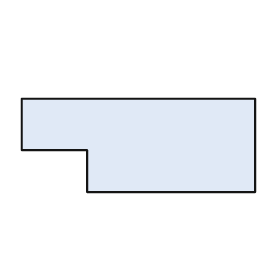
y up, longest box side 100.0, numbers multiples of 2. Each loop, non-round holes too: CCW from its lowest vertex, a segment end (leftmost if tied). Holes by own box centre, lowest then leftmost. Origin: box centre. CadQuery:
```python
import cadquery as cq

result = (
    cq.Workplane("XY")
    .moveTo(-22.0, -20.0)
    .lineTo(50.0, -20.0)
    .lineTo(50.0, 20.0)
    .lineTo(-50.0, 20.0)
    .lineTo(-50.0, -2.0)
    .lineTo(-22.0, -2.0)
    .close()
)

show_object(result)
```